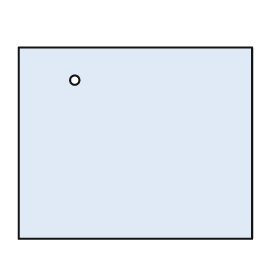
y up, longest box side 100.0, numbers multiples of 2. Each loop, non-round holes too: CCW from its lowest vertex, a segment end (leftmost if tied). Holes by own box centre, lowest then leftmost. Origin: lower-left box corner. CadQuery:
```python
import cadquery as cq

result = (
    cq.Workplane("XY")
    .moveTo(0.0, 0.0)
    .lineTo(100.0, 0.0)
    .lineTo(100.0, 82.0)
    .lineTo(0.0, 82.0)
    .close()
    .moveTo(24.0, 68.0)
    .circle(2.0)
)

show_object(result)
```